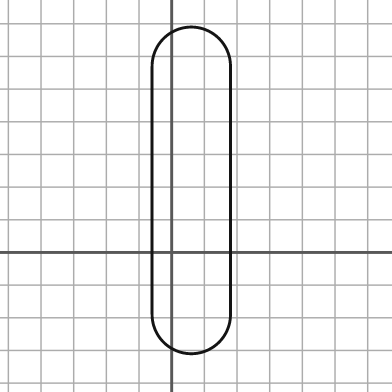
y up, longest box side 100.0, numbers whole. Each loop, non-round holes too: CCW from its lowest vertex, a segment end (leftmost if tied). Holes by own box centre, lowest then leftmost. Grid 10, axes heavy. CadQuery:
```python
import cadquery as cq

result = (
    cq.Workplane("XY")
    .moveTo(-6.0, -19.0)
    .threePointArc((6.0, -31.0), (18.0, -19.0))
    .lineTo(18.0, 57.0)
    .threePointArc((6.0, 69.0), (-6.0, 57.0))
    .close()
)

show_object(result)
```